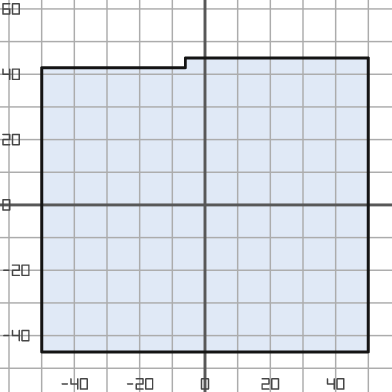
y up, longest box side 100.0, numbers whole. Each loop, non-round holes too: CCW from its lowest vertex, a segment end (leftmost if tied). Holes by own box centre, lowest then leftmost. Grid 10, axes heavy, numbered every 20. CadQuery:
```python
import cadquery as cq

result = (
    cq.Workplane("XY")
    .moveTo(-50.0, -45.0)
    .lineTo(50.0, -45.0)
    .lineTo(50.0, 45.0)
    .lineTo(-6.0, 45.0)
    .lineTo(-6.0, 42.0)
    .lineTo(-50.0, 42.0)
    .close()
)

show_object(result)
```